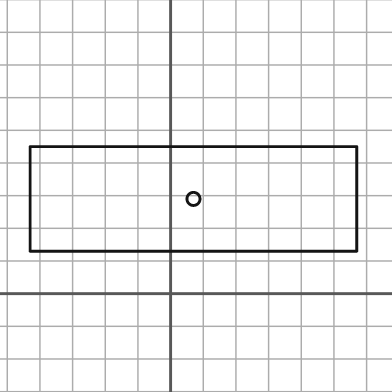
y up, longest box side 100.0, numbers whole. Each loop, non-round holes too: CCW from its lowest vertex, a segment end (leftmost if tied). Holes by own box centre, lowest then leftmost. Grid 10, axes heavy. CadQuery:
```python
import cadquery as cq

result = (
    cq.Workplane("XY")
    .moveTo(-43.0, 13.0)
    .lineTo(57.0, 13.0)
    .lineTo(57.0, 45.0)
    .lineTo(-43.0, 45.0)
    .close()
    .moveTo(7.0, 29.0)
    .circle(2.0)
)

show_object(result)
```